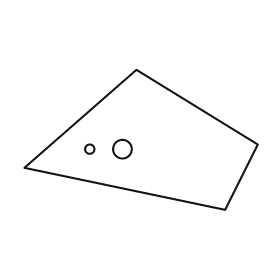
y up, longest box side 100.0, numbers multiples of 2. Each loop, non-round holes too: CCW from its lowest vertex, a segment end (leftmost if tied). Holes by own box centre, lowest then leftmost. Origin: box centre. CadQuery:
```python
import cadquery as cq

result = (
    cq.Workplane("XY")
    .moveTo(36.0, -30.0)
    .lineTo(50.0, -2.0)
    .lineTo(-2.0, 30.0)
    .lineTo(-50.0, -12.0)
    .close()
    .moveTo(-22.0, -4.0)
    .circle(2.0)
    .moveTo(-8.0, -4.0)
    .circle(4.0)
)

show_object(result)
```